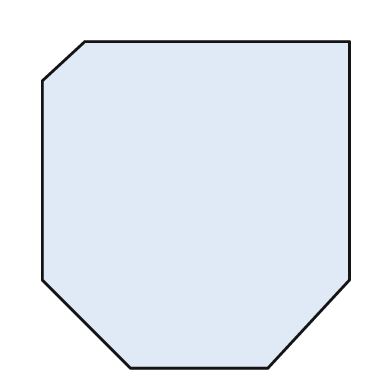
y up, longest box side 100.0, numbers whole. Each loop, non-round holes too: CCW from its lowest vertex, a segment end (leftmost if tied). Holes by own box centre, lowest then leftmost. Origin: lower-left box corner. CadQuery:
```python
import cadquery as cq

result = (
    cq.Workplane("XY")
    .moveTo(27.0, 0.0)
    .lineTo(69.0, 0.0)
    .lineTo(94.0, 27.0)
    .lineTo(94.0, 100.0)
    .lineTo(13.0, 100.0)
    .lineTo(0.0, 88.0)
    .lineTo(0.0, 27.0)
    .close()
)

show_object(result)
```